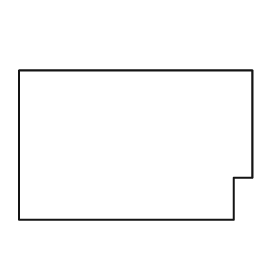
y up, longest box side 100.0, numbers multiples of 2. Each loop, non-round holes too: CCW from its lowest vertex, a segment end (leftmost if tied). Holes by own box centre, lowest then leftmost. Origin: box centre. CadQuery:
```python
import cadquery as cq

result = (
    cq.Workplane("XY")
    .moveTo(-50.0, -32.0)
    .lineTo(42.0, -32.0)
    .lineTo(42.0, -14.0)
    .lineTo(50.0, -14.0)
    .lineTo(50.0, 32.0)
    .lineTo(-50.0, 32.0)
    .close()
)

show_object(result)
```